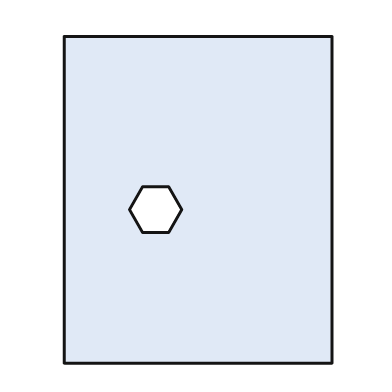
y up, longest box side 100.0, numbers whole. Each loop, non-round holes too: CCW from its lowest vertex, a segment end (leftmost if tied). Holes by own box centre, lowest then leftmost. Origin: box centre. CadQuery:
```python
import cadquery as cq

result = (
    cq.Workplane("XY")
    .moveTo(-41.0, -50.0)
    .lineTo(41.0, -50.0)
    .lineTo(41.0, 50.0)
    .lineTo(-41.0, 50.0)
    .close()
    .moveTo(-17.0, -10.0)
    .lineTo(-9.0, -10.0)
    .lineTo(-5.0, -3.0)
    .lineTo(-9.0, 4.0)
    .lineTo(-17.0, 4.0)
    .lineTo(-21.0, -3.0)
    .close()
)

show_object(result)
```